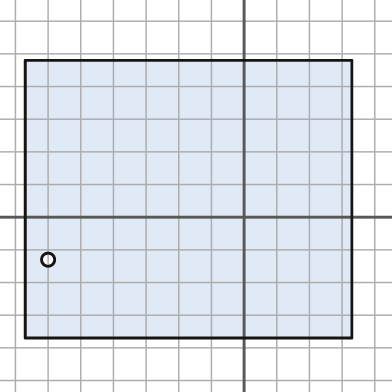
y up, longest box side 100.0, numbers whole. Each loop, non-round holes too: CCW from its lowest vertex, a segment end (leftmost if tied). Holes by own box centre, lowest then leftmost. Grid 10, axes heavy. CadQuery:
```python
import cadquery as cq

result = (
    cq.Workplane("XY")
    .moveTo(-67.0, -37.0)
    .lineTo(33.0, -37.0)
    .lineTo(33.0, 48.0)
    .lineTo(-67.0, 48.0)
    .close()
    .moveTo(-60.0, -13.0)
    .circle(2.0)
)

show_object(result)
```